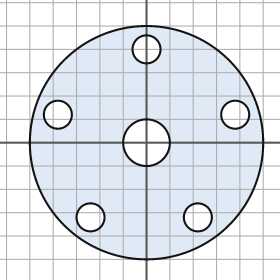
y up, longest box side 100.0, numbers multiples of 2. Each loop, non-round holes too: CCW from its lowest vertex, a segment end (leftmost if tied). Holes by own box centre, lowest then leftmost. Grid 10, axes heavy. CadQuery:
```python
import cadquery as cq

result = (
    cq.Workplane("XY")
    .moveTo(0.0, 0.0)
    .circle(50.0)
    .moveTo(-24.0, -32.0)
    .circle(6.0)
    .moveTo(22.0, -32.0)
    .circle(6.0)
    .moveTo(0.0, 0.0)
    .circle(10.0)
    .moveTo(-38.0, 12.0)
    .circle(6.0)
    .moveTo(38.0, 12.0)
    .circle(6.0)
    .moveTo(0.0, 40.0)
    .circle(6.0)
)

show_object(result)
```